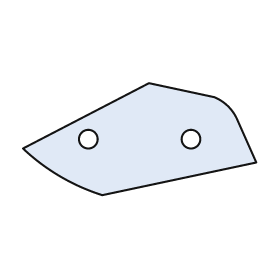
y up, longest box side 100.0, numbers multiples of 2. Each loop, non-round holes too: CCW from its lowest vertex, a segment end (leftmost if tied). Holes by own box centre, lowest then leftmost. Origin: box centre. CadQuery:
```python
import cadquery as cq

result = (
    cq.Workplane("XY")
    .moveTo(-16.0, -24.0)
    .lineTo(50.0, -10.0)
    .lineTo(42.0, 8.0)
    .threePointArc((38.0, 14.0), (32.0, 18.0))
    .lineTo(4.0, 24.0)
    .lineTo(-50.0, -4.0)
    .threePointArc((-34.0, -16.0), (-16.0, -24.0))
    .close()
    .moveTo(-22.0, 0.0)
    .circle(4.0)
    .moveTo(22.0, 0.0)
    .circle(4.0)
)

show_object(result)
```